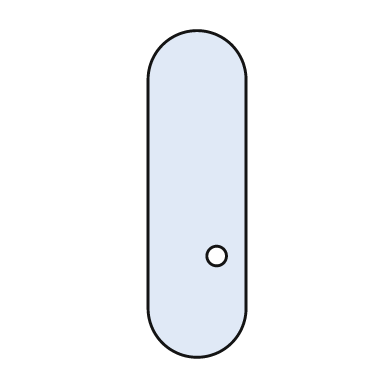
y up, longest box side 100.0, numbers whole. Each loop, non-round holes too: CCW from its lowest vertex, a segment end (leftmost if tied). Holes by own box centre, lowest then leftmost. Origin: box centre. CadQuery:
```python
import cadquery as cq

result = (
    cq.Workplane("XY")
    .moveTo(-15.0, -35.0)
    .threePointArc((0.0, -50.0), (15.0, -35.0))
    .lineTo(15.0, 35.0)
    .threePointArc((0.0, 50.0), (-15.0, 35.0))
    .close()
    .moveTo(6.0, -19.0)
    .circle(3.0)
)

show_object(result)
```